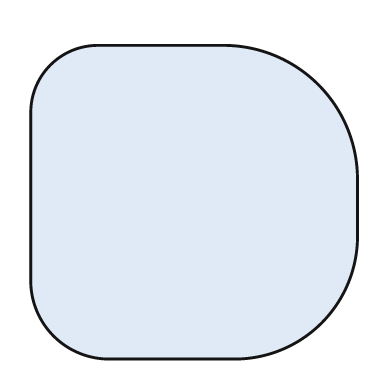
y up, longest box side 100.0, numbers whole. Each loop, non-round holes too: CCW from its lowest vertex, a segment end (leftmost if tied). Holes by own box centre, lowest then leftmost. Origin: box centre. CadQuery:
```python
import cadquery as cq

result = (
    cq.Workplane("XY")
    .moveTo(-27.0, -48.0)
    .lineTo(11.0, -48.0)
    .threePointArc((39.0, -37.0), (50.0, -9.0))
    .lineTo(50.0, 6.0)
    .threePointArc((38.0, 36.0), (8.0, 48.0))
    .lineTo(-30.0, 48.0)
    .threePointArc((-44.0, 42.0), (-50.0, 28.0))
    .lineTo(-50.0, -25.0)
    .threePointArc((-43.0, -41.0), (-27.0, -48.0))
    .close()
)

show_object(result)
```